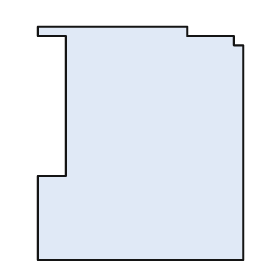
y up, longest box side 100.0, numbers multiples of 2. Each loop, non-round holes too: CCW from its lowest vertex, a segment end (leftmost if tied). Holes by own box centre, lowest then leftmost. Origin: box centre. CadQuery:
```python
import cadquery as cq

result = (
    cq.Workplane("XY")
    .moveTo(-44.0, -50.0)
    .lineTo(44.0, -50.0)
    .lineTo(44.0, 42.0)
    .lineTo(40.0, 42.0)
    .lineTo(40.0, 46.0)
    .lineTo(20.0, 46.0)
    .lineTo(20.0, 50.0)
    .lineTo(-44.0, 50.0)
    .lineTo(-44.0, 46.0)
    .lineTo(-32.0, 46.0)
    .lineTo(-32.0, -14.0)
    .lineTo(-44.0, -14.0)
    .close()
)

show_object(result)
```